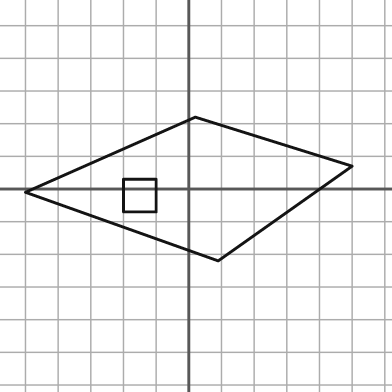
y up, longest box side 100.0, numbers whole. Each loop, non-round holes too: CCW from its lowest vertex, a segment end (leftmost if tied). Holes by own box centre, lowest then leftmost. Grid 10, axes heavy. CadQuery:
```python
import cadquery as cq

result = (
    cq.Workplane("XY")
    .moveTo(9.0, -22.0)
    .lineTo(50.0, 7.0)
    .lineTo(2.0, 22.0)
    .lineTo(-50.0, -1.0)
    .close()
    .moveTo(-20.0, -7.0)
    .lineTo(-10.0, -7.0)
    .lineTo(-10.0, 3.0)
    .lineTo(-20.0, 3.0)
    .close()
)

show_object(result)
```